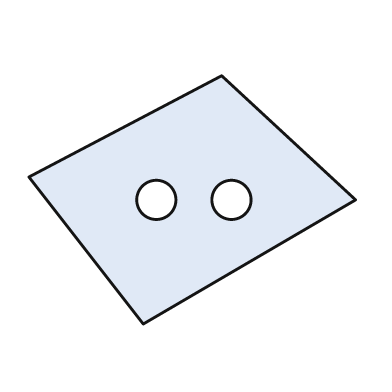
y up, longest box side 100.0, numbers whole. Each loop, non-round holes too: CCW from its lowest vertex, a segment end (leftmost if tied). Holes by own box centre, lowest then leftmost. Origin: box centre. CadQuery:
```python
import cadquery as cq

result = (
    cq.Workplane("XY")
    .moveTo(-15.0, -38.0)
    .lineTo(50.0, 0.0)
    .lineTo(9.0, 38.0)
    .lineTo(-50.0, 7.0)
    .close()
    .moveTo(-11.0, 0.0)
    .circle(6.0)
    .moveTo(12.0, 0.0)
    .circle(6.0)
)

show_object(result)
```